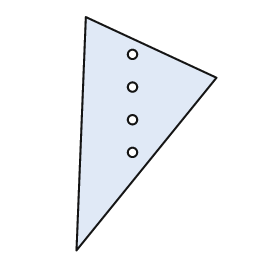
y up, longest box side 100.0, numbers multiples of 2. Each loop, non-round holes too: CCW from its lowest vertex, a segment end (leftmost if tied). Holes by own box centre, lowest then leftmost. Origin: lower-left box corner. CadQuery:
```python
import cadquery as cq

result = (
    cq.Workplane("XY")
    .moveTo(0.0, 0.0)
    .lineTo(60.0, 74.0)
    .lineTo(4.0, 100.0)
    .close()
    .moveTo(24.0, 42.0)
    .circle(2.0)
    .moveTo(24.0, 56.0)
    .circle(2.0)
    .moveTo(24.0, 70.0)
    .circle(2.0)
    .moveTo(24.0, 84.0)
    .circle(2.0)
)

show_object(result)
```